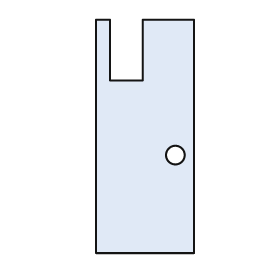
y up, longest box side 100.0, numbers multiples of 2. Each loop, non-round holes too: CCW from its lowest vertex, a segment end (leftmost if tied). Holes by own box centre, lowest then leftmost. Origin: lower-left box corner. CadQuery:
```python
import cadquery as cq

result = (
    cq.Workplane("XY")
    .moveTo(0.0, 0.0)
    .lineTo(42.0, 0.0)
    .lineTo(42.0, 100.0)
    .lineTo(20.0, 100.0)
    .lineTo(20.0, 74.0)
    .lineTo(6.0, 74.0)
    .lineTo(6.0, 100.0)
    .lineTo(0.0, 100.0)
    .close()
    .moveTo(34.0, 42.0)
    .circle(4.0)
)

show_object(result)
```